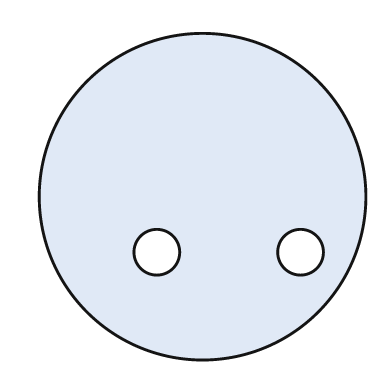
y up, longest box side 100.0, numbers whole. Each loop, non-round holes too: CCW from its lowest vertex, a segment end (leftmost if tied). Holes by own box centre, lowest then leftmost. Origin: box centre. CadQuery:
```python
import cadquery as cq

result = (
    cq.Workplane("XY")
    .moveTo(0.0, 0.0)
    .circle(50.0)
    .moveTo(-14.0, -17.0)
    .circle(7.0)
    .moveTo(30.0, -17.0)
    .circle(7.0)
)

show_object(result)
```